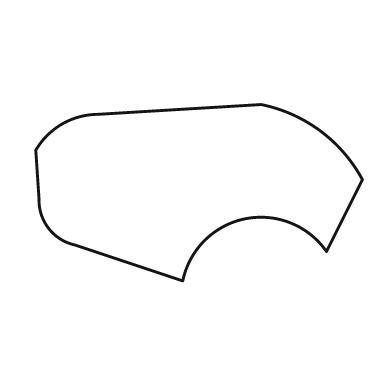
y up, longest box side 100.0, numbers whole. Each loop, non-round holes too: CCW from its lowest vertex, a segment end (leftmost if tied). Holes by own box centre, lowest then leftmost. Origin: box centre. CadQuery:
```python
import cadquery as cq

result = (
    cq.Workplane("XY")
    .moveTo(-5.0, -27.0)
    .threePointArc((14.0, -8.0), (39.0, -18.0))
    .lineTo(50.0, 4.0)
    .threePointArc((37.0, 19.0), (19.0, 27.0))
    .lineTo(-31.0, 24.0)
    .threePointArc((-42.0, 21.0), (-50.0, 13.0))
    .lineTo(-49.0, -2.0)
    .threePointArc((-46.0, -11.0), (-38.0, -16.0))
    .close()
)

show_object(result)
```